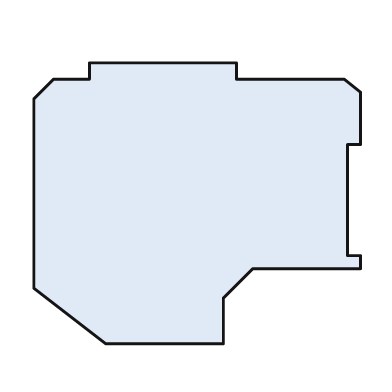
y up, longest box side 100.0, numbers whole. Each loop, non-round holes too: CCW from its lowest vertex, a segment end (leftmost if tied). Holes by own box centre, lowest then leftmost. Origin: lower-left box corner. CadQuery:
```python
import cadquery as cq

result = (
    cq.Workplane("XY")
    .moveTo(22.0, 0.0)
    .lineTo(58.0, 0.0)
    .lineTo(58.0, 14.0)
    .lineTo(67.0, 23.0)
    .lineTo(100.0, 23.0)
    .lineTo(100.0, 27.0)
    .lineTo(96.0, 27.0)
    .lineTo(96.0, 61.0)
    .lineTo(100.0, 61.0)
    .lineTo(100.0, 77.0)
    .lineTo(95.0, 81.0)
    .lineTo(62.0, 81.0)
    .lineTo(62.0, 86.0)
    .lineTo(17.0, 86.0)
    .lineTo(17.0, 81.0)
    .lineTo(6.0, 81.0)
    .lineTo(0.0, 75.0)
    .lineTo(0.0, 17.0)
    .close()
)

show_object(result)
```